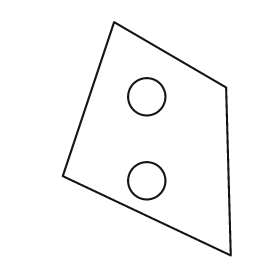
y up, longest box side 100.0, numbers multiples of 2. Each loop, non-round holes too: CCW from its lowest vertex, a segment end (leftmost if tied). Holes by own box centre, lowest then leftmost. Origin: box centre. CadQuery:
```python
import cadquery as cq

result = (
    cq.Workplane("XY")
    .moveTo(36.0, -50.0)
    .lineTo(34.0, 22.0)
    .lineTo(-14.0, 50.0)
    .lineTo(-36.0, -16.0)
    .close()
    .moveTo(0.0, -18.0)
    .circle(8.0)
    .moveTo(0.0, 18.0)
    .circle(8.0)
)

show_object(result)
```